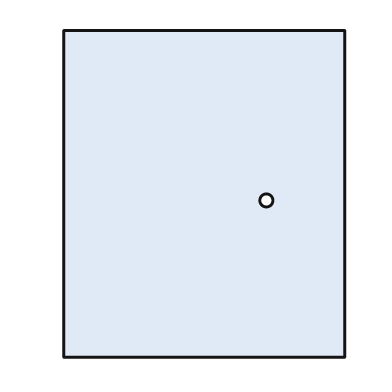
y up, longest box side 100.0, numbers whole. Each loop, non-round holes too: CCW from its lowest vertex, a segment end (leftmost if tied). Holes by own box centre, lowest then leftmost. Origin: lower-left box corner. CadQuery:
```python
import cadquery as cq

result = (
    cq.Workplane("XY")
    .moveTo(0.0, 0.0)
    .lineTo(86.0, 0.0)
    .lineTo(86.0, 100.0)
    .lineTo(0.0, 100.0)
    .close()
    .moveTo(62.0, 48.0)
    .circle(2.0)
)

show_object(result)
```